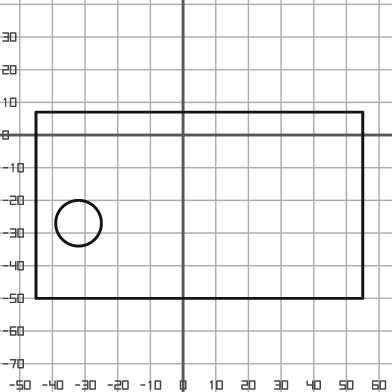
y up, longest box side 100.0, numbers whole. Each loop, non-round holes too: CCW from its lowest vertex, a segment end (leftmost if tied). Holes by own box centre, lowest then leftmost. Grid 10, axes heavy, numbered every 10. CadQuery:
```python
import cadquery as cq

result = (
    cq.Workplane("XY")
    .moveTo(-45.0, -50.0)
    .lineTo(55.0, -50.0)
    .lineTo(55.0, 7.0)
    .lineTo(-45.0, 7.0)
    .close()
    .moveTo(-32.0, -27.0)
    .circle(7.0)
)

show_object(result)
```